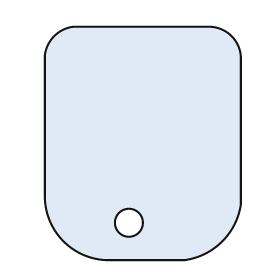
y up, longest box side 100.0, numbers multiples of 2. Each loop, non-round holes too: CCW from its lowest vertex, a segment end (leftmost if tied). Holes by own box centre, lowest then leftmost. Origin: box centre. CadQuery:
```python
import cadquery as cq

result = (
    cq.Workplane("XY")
    .moveTo(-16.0, -50.0)
    .lineTo(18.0, -50.0)
    .threePointArc((34.0, -42.0), (42.0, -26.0))
    .lineTo(42.0, 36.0)
    .threePointArc((38.0, 46.0), (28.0, 50.0))
    .lineTo(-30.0, 50.0)
    .threePointArc((-38.0, 46.0), (-42.0, 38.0))
    .lineTo(-42.0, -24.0)
    .threePointArc((-34.0, -42.0), (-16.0, -50.0))
    .close()
    .moveTo(-6.0, -34.0)
    .circle(6.0)
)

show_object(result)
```